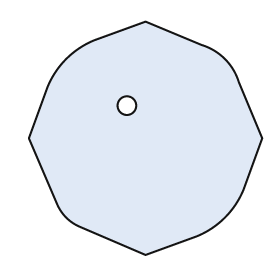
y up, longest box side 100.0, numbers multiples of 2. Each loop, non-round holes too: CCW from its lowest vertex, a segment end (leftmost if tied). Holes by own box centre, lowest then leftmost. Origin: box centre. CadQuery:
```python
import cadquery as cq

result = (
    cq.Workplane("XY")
    .moveTo(0.0, -50.0)
    .lineTo(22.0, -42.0)
    .threePointArc((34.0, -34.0), (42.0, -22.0))
    .lineTo(50.0, 0.0)
    .lineTo(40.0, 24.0)
    .threePointArc((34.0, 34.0), (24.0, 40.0))
    .lineTo(0.0, 50.0)
    .lineTo(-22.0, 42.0)
    .threePointArc((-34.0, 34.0), (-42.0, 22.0))
    .lineTo(-50.0, 0.0)
    .lineTo(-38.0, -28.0)
    .threePointArc((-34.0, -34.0), (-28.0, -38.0))
    .close()
    .moveTo(-8.0, 14.0)
    .circle(4.0)
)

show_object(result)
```